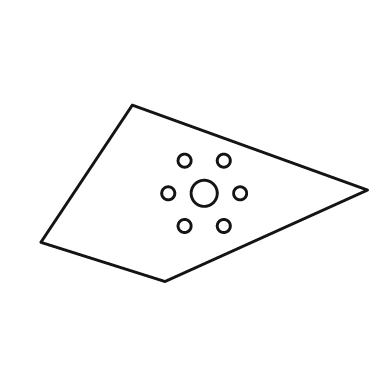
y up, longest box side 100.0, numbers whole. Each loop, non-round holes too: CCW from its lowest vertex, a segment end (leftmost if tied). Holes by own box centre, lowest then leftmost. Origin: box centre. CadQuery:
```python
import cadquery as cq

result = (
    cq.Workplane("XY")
    .moveTo(-12.0, -27.0)
    .lineTo(50.0, 1.0)
    .lineTo(-22.0, 27.0)
    .lineTo(-50.0, -15.0)
    .close()
    .moveTo(-6.0, -10.0)
    .circle(2.0)
    .moveTo(6.0, -10.0)
    .circle(2.0)
    .moveTo(-11.0, 0.0)
    .circle(2.0)
    .moveTo(0.0, 0.0)
    .circle(4.0)
    .moveTo(11.0, 0.0)
    .circle(2.0)
    .moveTo(-6.0, 10.0)
    .circle(2.0)
    .moveTo(6.0, 10.0)
    .circle(2.0)
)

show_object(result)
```